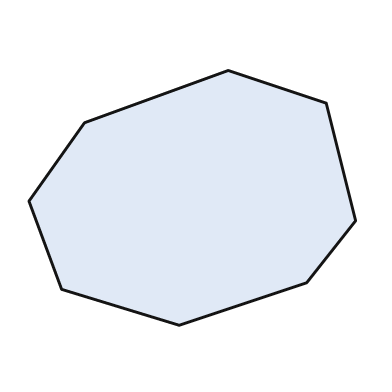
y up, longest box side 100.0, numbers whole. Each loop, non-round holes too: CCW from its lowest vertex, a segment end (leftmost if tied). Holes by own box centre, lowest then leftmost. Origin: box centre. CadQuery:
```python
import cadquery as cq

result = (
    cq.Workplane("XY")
    .moveTo(-4.0, -39.0)
    .lineTo(35.0, -26.0)
    .lineTo(50.0, -7.0)
    .lineTo(41.0, 29.0)
    .lineTo(11.0, 39.0)
    .lineTo(-33.0, 23.0)
    .lineTo(-50.0, -1.0)
    .lineTo(-40.0, -28.0)
    .close()
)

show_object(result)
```